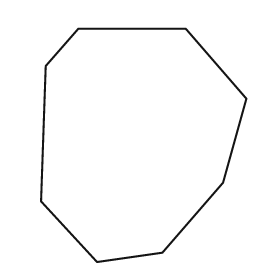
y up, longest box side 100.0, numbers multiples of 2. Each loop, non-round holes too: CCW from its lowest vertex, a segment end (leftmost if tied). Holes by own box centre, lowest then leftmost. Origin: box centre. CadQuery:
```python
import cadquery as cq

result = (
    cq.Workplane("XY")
    .moveTo(-20.0, -50.0)
    .lineTo(8.0, -46.0)
    .lineTo(34.0, -16.0)
    .lineTo(44.0, 20.0)
    .lineTo(18.0, 50.0)
    .lineTo(-28.0, 50.0)
    .lineTo(-42.0, 34.0)
    .lineTo(-44.0, -24.0)
    .close()
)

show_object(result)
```